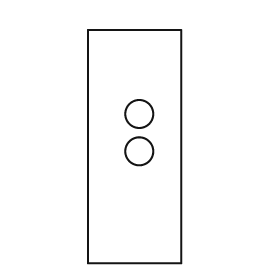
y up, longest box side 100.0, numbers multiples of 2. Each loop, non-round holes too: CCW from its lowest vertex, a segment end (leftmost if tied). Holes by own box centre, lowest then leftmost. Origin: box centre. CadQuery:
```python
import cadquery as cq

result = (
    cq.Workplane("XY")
    .moveTo(-20.0, -50.0)
    .lineTo(20.0, -50.0)
    .lineTo(20.0, 50.0)
    .lineTo(-20.0, 50.0)
    .close()
    .moveTo(2.0, -2.0)
    .circle(6.0)
    .moveTo(2.0, 14.0)
    .circle(6.0)
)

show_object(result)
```